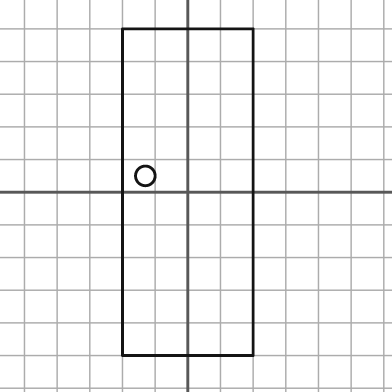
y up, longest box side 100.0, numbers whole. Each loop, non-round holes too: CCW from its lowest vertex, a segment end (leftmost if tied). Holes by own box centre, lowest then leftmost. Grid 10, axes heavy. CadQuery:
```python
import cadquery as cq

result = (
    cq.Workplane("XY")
    .moveTo(-20.0, -50.0)
    .lineTo(20.0, -50.0)
    .lineTo(20.0, 50.0)
    .lineTo(-20.0, 50.0)
    .close()
    .moveTo(-13.0, 5.0)
    .circle(3.0)
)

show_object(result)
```